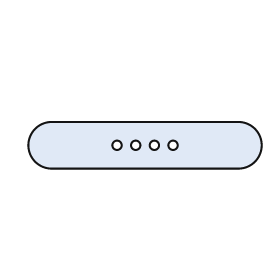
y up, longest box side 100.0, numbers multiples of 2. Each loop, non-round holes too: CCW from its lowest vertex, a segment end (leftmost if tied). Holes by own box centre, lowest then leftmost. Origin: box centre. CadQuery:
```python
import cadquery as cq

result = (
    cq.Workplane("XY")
    .moveTo(-40.0, -10.0)
    .lineTo(40.0, -10.0)
    .threePointArc((50.0, 0.0), (40.0, 10.0))
    .lineTo(-40.0, 10.0)
    .threePointArc((-50.0, 0.0), (-40.0, -10.0))
    .close()
    .moveTo(-12.0, 0.0)
    .circle(2.0)
    .moveTo(-4.0, 0.0)
    .circle(2.0)
    .moveTo(4.0, 0.0)
    .circle(2.0)
    .moveTo(12.0, 0.0)
    .circle(2.0)
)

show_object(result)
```